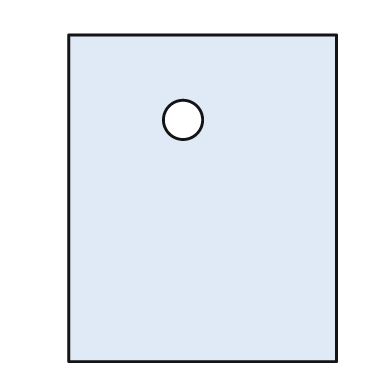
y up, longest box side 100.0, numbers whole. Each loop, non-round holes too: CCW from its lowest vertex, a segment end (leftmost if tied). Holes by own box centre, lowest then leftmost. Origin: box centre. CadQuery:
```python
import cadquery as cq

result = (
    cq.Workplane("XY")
    .moveTo(-41.0, -50.0)
    .lineTo(41.0, -50.0)
    .lineTo(41.0, 50.0)
    .lineTo(-41.0, 50.0)
    .close()
    .moveTo(-6.0, 24.0)
    .circle(6.0)
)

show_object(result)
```